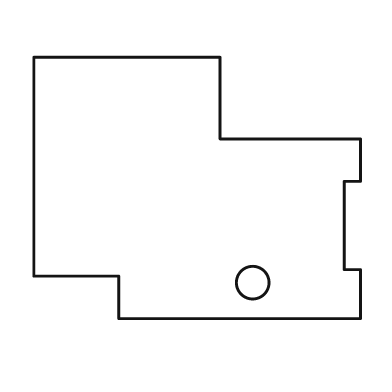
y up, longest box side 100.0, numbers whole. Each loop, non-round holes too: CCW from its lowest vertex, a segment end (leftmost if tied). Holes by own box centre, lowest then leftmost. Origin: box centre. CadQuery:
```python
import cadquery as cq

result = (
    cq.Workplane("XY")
    .moveTo(-24.0, -40.0)
    .lineTo(50.0, -40.0)
    .lineTo(50.0, -25.0)
    .lineTo(45.0, -25.0)
    .lineTo(45.0, 2.0)
    .lineTo(50.0, 2.0)
    .lineTo(50.0, 15.0)
    .lineTo(7.0, 15.0)
    .lineTo(7.0, 40.0)
    .lineTo(-50.0, 40.0)
    .lineTo(-50.0, -27.0)
    .lineTo(-24.0, -27.0)
    .close()
    .moveTo(17.0, -29.0)
    .circle(5.0)
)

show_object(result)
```